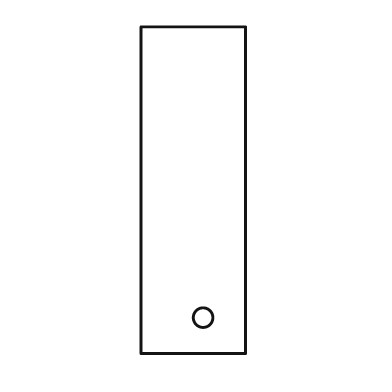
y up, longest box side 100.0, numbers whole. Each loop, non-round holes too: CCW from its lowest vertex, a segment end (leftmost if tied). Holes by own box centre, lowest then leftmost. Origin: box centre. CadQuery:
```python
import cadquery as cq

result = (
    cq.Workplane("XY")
    .moveTo(-16.0, -50.0)
    .lineTo(16.0, -50.0)
    .lineTo(16.0, 50.0)
    .lineTo(-16.0, 50.0)
    .close()
    .moveTo(3.0, -39.0)
    .circle(3.0)
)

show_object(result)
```